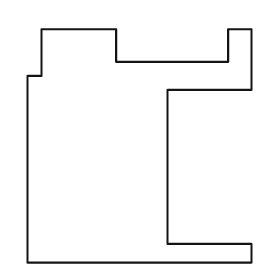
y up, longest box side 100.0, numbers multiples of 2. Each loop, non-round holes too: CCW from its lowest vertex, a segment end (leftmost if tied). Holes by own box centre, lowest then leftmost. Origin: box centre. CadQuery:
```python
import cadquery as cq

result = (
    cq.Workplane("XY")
    .moveTo(-48.0, -50.0)
    .lineTo(48.0, -50.0)
    .lineTo(48.0, -42.0)
    .lineTo(12.0, -42.0)
    .lineTo(12.0, 24.0)
    .lineTo(48.0, 24.0)
    .lineTo(48.0, 50.0)
    .lineTo(38.0, 50.0)
    .lineTo(38.0, 36.0)
    .lineTo(-10.0, 36.0)
    .lineTo(-10.0, 50.0)
    .lineTo(-42.0, 50.0)
    .lineTo(-42.0, 30.0)
    .lineTo(-48.0, 30.0)
    .close()
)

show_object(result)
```